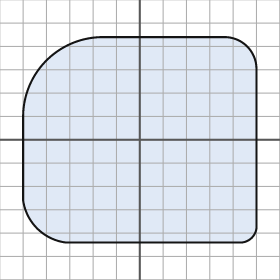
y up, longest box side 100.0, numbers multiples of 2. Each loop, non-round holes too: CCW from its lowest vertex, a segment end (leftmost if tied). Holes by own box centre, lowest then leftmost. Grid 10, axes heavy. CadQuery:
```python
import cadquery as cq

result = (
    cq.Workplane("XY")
    .moveTo(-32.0, -44.0)
    .lineTo(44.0, -44.0)
    .threePointArc((48.0, -42.0), (50.0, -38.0))
    .lineTo(50.0, 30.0)
    .threePointArc((46.0, 40.0), (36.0, 44.0))
    .lineTo(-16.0, 44.0)
    .threePointArc((-40.0, 34.0), (-50.0, 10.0))
    .lineTo(-50.0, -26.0)
    .threePointArc((-44.0, -38.0), (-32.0, -44.0))
    .close()
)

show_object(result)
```